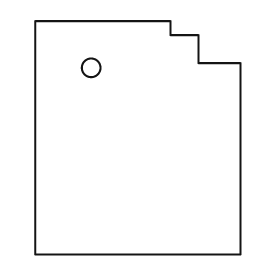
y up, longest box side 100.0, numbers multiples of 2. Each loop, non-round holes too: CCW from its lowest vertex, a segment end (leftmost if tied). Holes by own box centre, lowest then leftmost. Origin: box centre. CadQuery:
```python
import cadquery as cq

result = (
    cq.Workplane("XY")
    .moveTo(-44.0, -50.0)
    .lineTo(44.0, -50.0)
    .lineTo(44.0, 32.0)
    .lineTo(26.0, 32.0)
    .lineTo(26.0, 44.0)
    .lineTo(14.0, 44.0)
    .lineTo(14.0, 50.0)
    .lineTo(-44.0, 50.0)
    .close()
    .moveTo(-20.0, 30.0)
    .circle(4.0)
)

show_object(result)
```